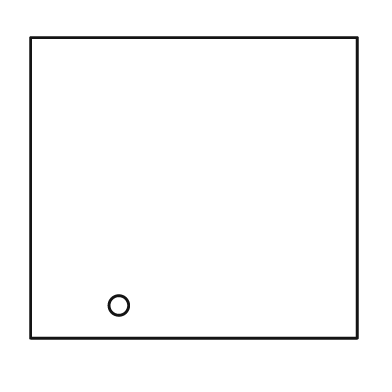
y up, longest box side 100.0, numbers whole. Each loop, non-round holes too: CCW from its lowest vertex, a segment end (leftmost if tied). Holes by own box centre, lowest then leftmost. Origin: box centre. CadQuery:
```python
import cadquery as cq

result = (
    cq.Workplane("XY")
    .moveTo(-50.0, -46.0)
    .lineTo(50.0, -46.0)
    .lineTo(50.0, 46.0)
    .lineTo(-50.0, 46.0)
    .close()
    .moveTo(-23.0, -36.0)
    .circle(3.0)
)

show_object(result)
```